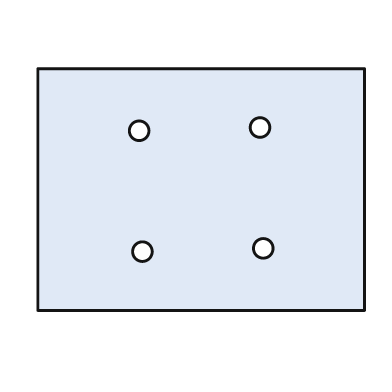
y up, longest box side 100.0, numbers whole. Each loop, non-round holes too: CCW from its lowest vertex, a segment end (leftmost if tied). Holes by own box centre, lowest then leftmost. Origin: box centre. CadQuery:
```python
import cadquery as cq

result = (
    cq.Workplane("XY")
    .moveTo(-50.0, -37.0)
    .lineTo(50.0, -37.0)
    .lineTo(50.0, 37.0)
    .lineTo(-50.0, 37.0)
    .close()
    .moveTo(-18.0, -19.0)
    .circle(3.0)
    .moveTo(19.0, -18.0)
    .circle(3.0)
    .moveTo(-19.0, 18.0)
    .circle(3.0)
    .moveTo(18.0, 19.0)
    .circle(3.0)
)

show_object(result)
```